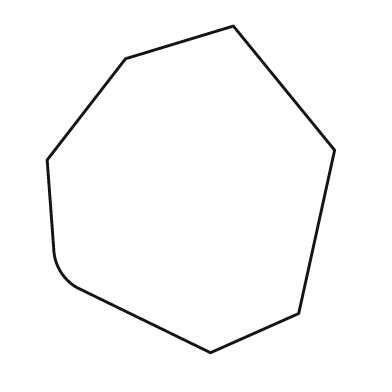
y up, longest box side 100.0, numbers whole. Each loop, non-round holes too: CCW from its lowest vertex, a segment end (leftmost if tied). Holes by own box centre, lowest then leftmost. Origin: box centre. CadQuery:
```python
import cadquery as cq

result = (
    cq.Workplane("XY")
    .moveTo(6.0, -50.0)
    .lineTo(33.0, -38.0)
    .lineTo(44.0, 12.0)
    .lineTo(13.0, 50.0)
    .lineTo(-20.0, 40.0)
    .lineTo(-44.0, 9.0)
    .lineTo(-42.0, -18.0)
    .threePointArc((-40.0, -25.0), (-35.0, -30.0))
    .close()
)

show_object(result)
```